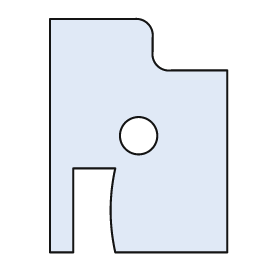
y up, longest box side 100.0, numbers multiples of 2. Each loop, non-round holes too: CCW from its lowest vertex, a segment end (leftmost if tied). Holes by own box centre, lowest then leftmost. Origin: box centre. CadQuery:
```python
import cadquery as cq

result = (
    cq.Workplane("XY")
    .moveTo(-38.0, -50.0)
    .lineTo(-28.0, -50.0)
    .lineTo(-28.0, -14.0)
    .lineTo(-10.0, -14.0)
    .threePointArc((-12.0, -32.0), (-10.0, -50.0))
    .lineTo(38.0, -50.0)
    .lineTo(38.0, 28.0)
    .lineTo(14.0, 28.0)
    .threePointArc((8.0, 30.0), (6.0, 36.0))
    .lineTo(6.0, 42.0)
    .threePointArc((4.0, 48.0), (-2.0, 50.0))
    .lineTo(-38.0, 50.0)
    .close()
    .moveTo(0.0, 0.0)
    .circle(8.0)
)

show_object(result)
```